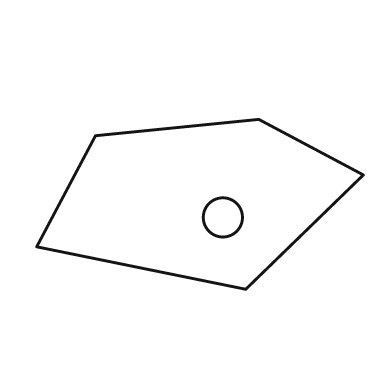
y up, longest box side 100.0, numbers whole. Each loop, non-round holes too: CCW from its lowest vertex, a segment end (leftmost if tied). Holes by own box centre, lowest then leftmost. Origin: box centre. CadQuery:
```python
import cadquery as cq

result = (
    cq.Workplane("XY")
    .moveTo(14.0, -26.0)
    .lineTo(50.0, 9.0)
    .lineTo(18.0, 26.0)
    .lineTo(-32.0, 21.0)
    .lineTo(-50.0, -13.0)
    .close()
    .moveTo(7.0, -4.0)
    .circle(6.0)
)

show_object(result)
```